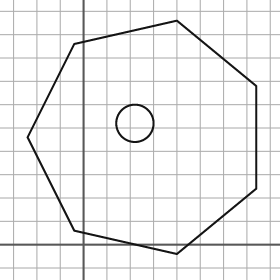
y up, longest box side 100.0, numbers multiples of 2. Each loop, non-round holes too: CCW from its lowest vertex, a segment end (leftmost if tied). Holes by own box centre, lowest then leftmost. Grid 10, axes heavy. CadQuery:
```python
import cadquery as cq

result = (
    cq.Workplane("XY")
    .moveTo(40.0, -4.0)
    .lineTo(74.0, 24.0)
    .lineTo(74.0, 68.0)
    .lineTo(40.0, 96.0)
    .lineTo(-4.0, 86.0)
    .lineTo(-24.0, 46.0)
    .lineTo(-4.0, 6.0)
    .close()
    .moveTo(22.0, 52.0)
    .circle(8.0)
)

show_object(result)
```